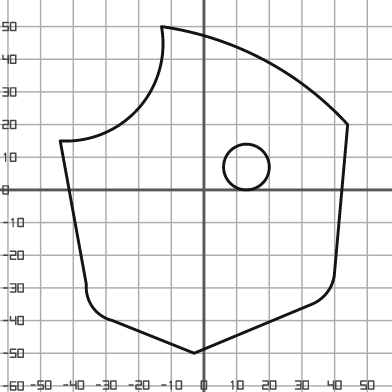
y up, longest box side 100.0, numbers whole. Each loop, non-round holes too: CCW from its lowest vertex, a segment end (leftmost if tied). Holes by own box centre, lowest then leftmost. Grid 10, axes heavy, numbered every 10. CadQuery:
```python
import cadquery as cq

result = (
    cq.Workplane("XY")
    .moveTo(-3.0, -50.0)
    .lineTo(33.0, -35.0)
    .threePointArc((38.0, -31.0), (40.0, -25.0))
    .lineTo(44.0, 20.0)
    .threePointArc((18.0, 40.0), (-13.0, 50.0))
    .threePointArc((-20.0, 25.0), (-44.0, 15.0))
    .lineTo(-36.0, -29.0)
    .threePointArc((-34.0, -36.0), (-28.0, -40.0))
    .close()
    .moveTo(13.0, 7.0)
    .circle(7.0)
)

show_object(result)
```